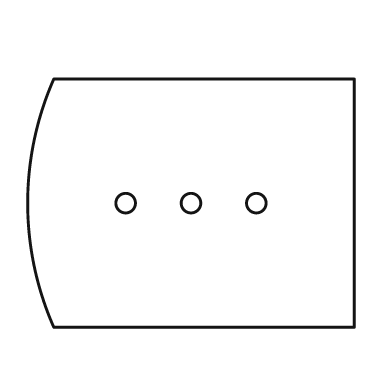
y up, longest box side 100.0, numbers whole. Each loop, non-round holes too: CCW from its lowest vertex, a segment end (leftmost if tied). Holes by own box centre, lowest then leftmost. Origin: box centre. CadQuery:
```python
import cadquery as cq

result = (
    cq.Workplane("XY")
    .moveTo(-42.0, -38.0)
    .lineTo(50.0, -38.0)
    .lineTo(50.0, 38.0)
    .lineTo(-42.0, 38.0)
    .threePointArc((-50.0, 0.0), (-42.0, -38.0))
    .close()
    .moveTo(-20.0, 0.0)
    .circle(3.0)
    .moveTo(0.0, 0.0)
    .circle(3.0)
    .moveTo(20.0, 0.0)
    .circle(3.0)
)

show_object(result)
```